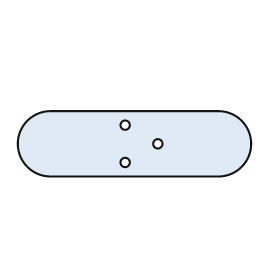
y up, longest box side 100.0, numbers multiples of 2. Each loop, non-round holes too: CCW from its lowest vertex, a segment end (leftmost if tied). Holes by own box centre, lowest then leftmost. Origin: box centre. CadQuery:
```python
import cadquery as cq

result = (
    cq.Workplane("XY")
    .moveTo(-36.0, -14.0)
    .lineTo(36.0, -14.0)
    .threePointArc((50.0, 0.0), (36.0, 14.0))
    .lineTo(-36.0, 14.0)
    .threePointArc((-50.0, 0.0), (-36.0, -14.0))
    .close()
    .moveTo(-4.0, -8.0)
    .circle(2.0)
    .moveTo(10.0, 0.0)
    .circle(2.0)
    .moveTo(-4.0, 8.0)
    .circle(2.0)
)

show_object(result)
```